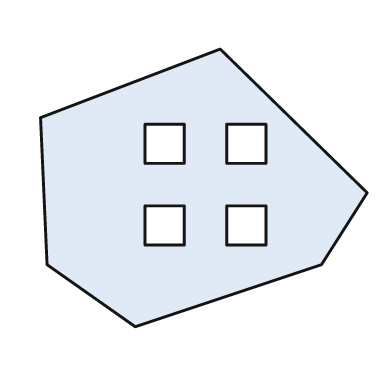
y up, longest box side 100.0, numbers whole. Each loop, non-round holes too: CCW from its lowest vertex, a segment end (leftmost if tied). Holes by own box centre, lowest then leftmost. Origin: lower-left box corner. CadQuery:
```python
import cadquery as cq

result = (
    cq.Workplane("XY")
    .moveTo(29.0, 0.0)
    .lineTo(86.0, 19.0)
    .lineTo(100.0, 41.0)
    .lineTo(55.0, 85.0)
    .lineTo(0.0, 64.0)
    .lineTo(2.0, 19.0)
    .close()
    .moveTo(32.0, 25.0)
    .lineTo(44.0, 25.0)
    .lineTo(44.0, 37.0)
    .lineTo(32.0, 37.0)
    .close()
    .moveTo(57.0, 25.0)
    .lineTo(69.0, 25.0)
    .lineTo(69.0, 37.0)
    .lineTo(57.0, 37.0)
    .close()
    .moveTo(32.0, 50.0)
    .lineTo(44.0, 50.0)
    .lineTo(44.0, 62.0)
    .lineTo(32.0, 62.0)
    .close()
    .moveTo(57.0, 50.0)
    .lineTo(69.0, 50.0)
    .lineTo(69.0, 62.0)
    .lineTo(57.0, 62.0)
    .close()
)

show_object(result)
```